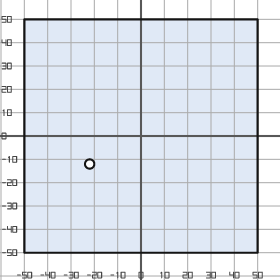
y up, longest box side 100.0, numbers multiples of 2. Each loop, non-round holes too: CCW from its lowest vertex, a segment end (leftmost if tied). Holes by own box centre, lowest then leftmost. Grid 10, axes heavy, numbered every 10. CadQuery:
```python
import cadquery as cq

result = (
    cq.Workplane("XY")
    .moveTo(-50.0, -50.0)
    .lineTo(50.0, -50.0)
    .lineTo(50.0, 50.0)
    .lineTo(-50.0, 50.0)
    .close()
    .moveTo(-22.0, -12.0)
    .circle(2.0)
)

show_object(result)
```